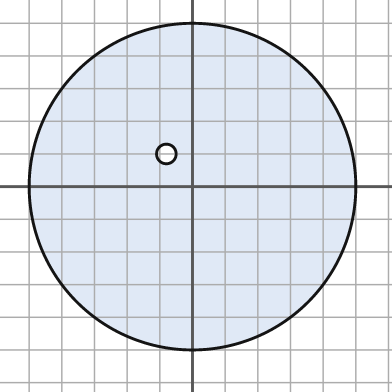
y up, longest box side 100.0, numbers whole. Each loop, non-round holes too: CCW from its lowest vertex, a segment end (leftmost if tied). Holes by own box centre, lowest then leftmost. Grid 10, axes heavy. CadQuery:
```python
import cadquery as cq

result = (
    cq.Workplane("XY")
    .moveTo(0.0, 0.0)
    .circle(50.0)
    .moveTo(-8.0, 10.0)
    .circle(3.0)
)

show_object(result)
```